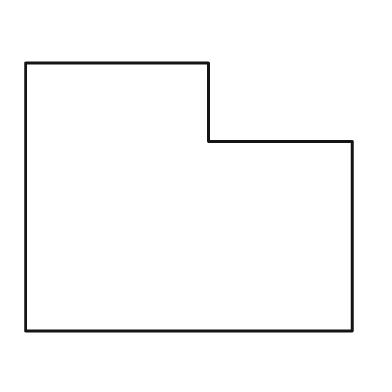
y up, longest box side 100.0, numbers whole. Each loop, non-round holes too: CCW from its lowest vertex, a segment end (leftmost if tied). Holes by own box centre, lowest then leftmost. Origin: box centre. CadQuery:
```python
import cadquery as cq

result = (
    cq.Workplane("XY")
    .moveTo(-50.0, -41.0)
    .lineTo(50.0, -41.0)
    .lineTo(50.0, 17.0)
    .lineTo(6.0, 17.0)
    .lineTo(6.0, 41.0)
    .lineTo(-50.0, 41.0)
    .close()
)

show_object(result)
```